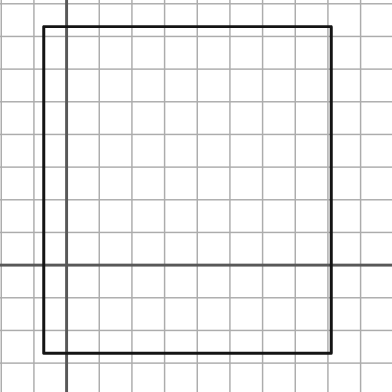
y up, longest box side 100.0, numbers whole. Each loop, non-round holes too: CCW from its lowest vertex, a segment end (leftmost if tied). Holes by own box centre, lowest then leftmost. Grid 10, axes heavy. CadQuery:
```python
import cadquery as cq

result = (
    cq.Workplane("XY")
    .moveTo(-7.0, -27.0)
    .lineTo(81.0, -27.0)
    .lineTo(81.0, 73.0)
    .lineTo(-7.0, 73.0)
    .close()
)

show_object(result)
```